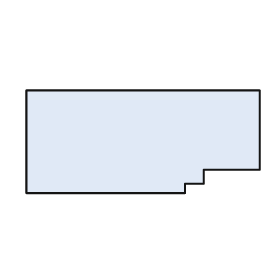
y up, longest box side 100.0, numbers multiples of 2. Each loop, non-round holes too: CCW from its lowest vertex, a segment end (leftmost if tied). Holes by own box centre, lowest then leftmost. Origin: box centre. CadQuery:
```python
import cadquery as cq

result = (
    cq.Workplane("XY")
    .moveTo(-50.0, -22.0)
    .lineTo(18.0, -22.0)
    .lineTo(18.0, -18.0)
    .lineTo(26.0, -18.0)
    .lineTo(26.0, -12.0)
    .lineTo(50.0, -12.0)
    .lineTo(50.0, 22.0)
    .lineTo(-50.0, 22.0)
    .close()
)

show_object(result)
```